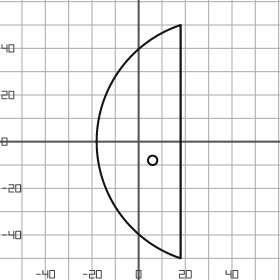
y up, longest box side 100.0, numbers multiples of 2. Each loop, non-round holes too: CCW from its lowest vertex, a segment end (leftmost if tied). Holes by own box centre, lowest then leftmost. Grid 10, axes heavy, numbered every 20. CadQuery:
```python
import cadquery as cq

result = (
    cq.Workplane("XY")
    .moveTo(18.0, -50.0)
    .lineTo(18.0, 50.0)
    .threePointArc((-18.0, 0.0), (18.0, -50.0))
    .close()
    .moveTo(6.0, -8.0)
    .circle(2.0)
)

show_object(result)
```